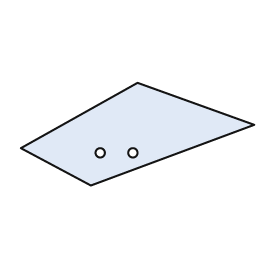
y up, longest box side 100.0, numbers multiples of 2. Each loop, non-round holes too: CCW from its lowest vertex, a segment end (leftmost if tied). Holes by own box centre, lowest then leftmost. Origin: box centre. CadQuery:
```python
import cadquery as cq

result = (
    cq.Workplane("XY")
    .moveTo(-20.0, -22.0)
    .lineTo(50.0, 4.0)
    .lineTo(0.0, 22.0)
    .lineTo(-50.0, -6.0)
    .close()
    .moveTo(-16.0, -8.0)
    .circle(2.0)
    .moveTo(-2.0, -8.0)
    .circle(2.0)
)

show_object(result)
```